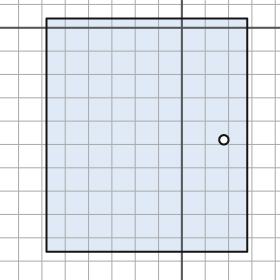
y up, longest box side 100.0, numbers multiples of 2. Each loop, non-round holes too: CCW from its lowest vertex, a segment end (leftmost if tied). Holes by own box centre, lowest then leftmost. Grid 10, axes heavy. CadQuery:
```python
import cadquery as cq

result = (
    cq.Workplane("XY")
    .moveTo(-58.0, -96.0)
    .lineTo(28.0, -96.0)
    .lineTo(28.0, 4.0)
    .lineTo(-58.0, 4.0)
    .close()
    .moveTo(18.0, -48.0)
    .circle(2.0)
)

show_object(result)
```